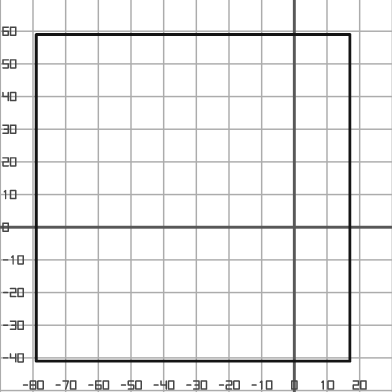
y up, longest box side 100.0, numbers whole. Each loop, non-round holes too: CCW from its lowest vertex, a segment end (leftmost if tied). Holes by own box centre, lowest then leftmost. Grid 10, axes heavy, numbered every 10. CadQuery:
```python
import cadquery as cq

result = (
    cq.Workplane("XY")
    .moveTo(-79.0, -41.0)
    .lineTo(17.0, -41.0)
    .lineTo(17.0, 59.0)
    .lineTo(-79.0, 59.0)
    .close()
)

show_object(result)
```